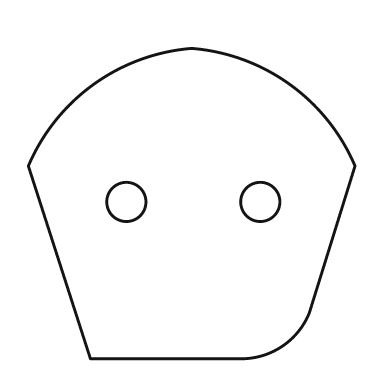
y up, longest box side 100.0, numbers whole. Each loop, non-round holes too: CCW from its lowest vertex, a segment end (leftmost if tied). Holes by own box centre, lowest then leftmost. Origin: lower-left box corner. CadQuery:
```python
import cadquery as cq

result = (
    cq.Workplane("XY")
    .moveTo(19.0, 0.0)
    .lineTo(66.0, 0.0)
    .threePointArc((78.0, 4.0), (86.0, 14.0))
    .lineTo(100.0, 59.0)
    .threePointArc((80.0, 84.0), (50.0, 95.0))
    .threePointArc((20.0, 84.0), (0.0, 59.0))
    .close()
    .moveTo(30.0, 48.0)
    .circle(6.0)
    .moveTo(71.0, 48.0)
    .circle(6.0)
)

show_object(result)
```